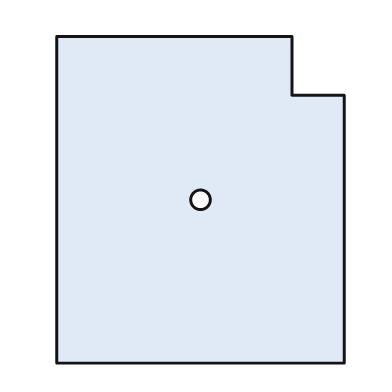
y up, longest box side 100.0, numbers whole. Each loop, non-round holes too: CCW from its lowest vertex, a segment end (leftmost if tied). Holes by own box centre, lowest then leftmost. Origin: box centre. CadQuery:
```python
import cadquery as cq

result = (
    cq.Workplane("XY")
    .moveTo(-44.0, -50.0)
    .lineTo(44.0, -50.0)
    .lineTo(44.0, 32.0)
    .lineTo(28.0, 32.0)
    .lineTo(28.0, 50.0)
    .lineTo(-44.0, 50.0)
    .close()
    .moveTo(0.0, 0.0)
    .circle(3.0)
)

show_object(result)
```